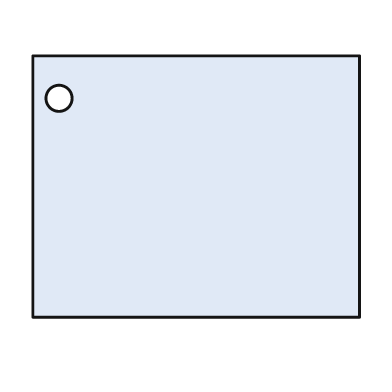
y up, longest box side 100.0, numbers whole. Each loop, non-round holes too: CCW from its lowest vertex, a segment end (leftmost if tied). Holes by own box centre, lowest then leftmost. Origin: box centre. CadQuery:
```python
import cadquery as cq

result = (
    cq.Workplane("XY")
    .moveTo(-50.0, -40.0)
    .lineTo(50.0, -40.0)
    .lineTo(50.0, 40.0)
    .lineTo(-50.0, 40.0)
    .close()
    .moveTo(-42.0, 27.0)
    .circle(4.0)
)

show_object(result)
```